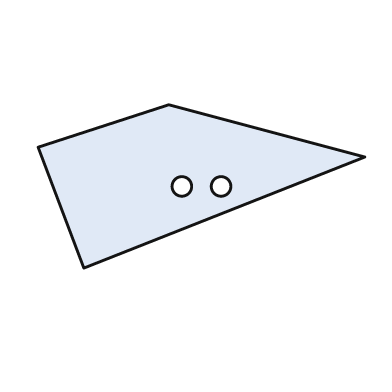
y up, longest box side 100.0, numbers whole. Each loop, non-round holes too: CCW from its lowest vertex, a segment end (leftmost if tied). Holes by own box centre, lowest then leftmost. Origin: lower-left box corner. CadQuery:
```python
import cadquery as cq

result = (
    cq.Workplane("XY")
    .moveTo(14.0, 0.0)
    .lineTo(100.0, 34.0)
    .lineTo(40.0, 50.0)
    .lineTo(0.0, 37.0)
    .close()
    .moveTo(44.0, 25.0)
    .circle(3.0)
    .moveTo(56.0, 25.0)
    .circle(3.0)
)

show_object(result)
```